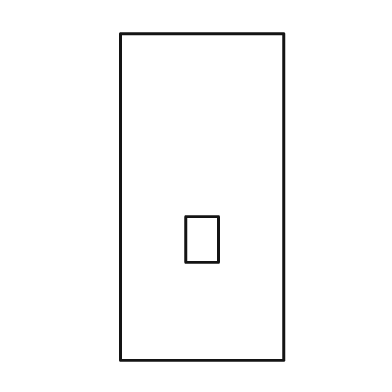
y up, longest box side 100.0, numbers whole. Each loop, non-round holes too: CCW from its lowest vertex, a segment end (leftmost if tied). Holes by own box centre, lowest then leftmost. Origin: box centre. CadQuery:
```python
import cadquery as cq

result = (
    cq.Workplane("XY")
    .moveTo(-25.0, -50.0)
    .lineTo(25.0, -50.0)
    .lineTo(25.0, 50.0)
    .lineTo(-25.0, 50.0)
    .close()
    .moveTo(-5.0, -20.0)
    .lineTo(5.0, -20.0)
    .lineTo(5.0, -6.0)
    .lineTo(-5.0, -6.0)
    .close()
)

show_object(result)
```